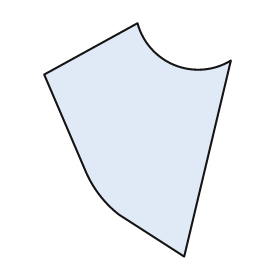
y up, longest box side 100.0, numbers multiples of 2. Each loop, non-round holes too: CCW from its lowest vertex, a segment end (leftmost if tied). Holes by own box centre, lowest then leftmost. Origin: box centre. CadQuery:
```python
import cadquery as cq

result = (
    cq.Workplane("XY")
    .moveTo(20.0, -50.0)
    .lineTo(40.0, 34.0)
    .threePointArc((16.0, 32.0), (0.0, 50.0))
    .lineTo(-40.0, 28.0)
    .lineTo(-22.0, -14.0)
    .threePointArc((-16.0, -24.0), (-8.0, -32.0))
    .close()
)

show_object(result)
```